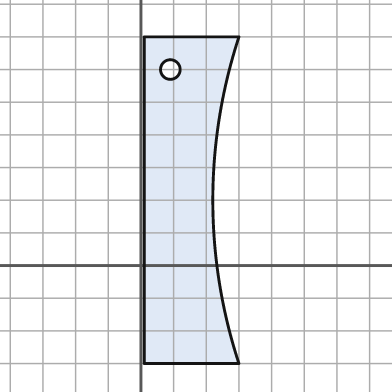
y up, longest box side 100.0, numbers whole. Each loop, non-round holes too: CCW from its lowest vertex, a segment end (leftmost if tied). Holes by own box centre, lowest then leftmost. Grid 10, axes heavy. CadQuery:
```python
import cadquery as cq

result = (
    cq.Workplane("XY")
    .moveTo(1.0, -30.0)
    .lineTo(30.0, -30.0)
    .threePointArc((22.0, 20.0), (30.0, 70.0))
    .lineTo(1.0, 70.0)
    .close()
    .moveTo(9.0, 60.0)
    .circle(3.0)
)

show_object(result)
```